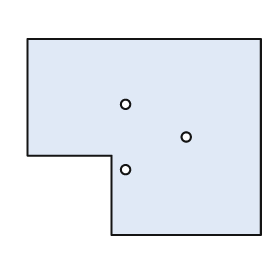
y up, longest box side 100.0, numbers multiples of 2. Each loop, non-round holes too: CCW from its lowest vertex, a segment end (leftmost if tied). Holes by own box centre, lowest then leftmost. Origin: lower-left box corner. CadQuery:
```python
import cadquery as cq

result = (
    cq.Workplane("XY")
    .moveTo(36.0, 0.0)
    .lineTo(100.0, 0.0)
    .lineTo(100.0, 84.0)
    .lineTo(0.0, 84.0)
    .lineTo(0.0, 34.0)
    .lineTo(36.0, 34.0)
    .close()
    .moveTo(42.0, 28.0)
    .circle(2.0)
    .moveTo(68.0, 42.0)
    .circle(2.0)
    .moveTo(42.0, 56.0)
    .circle(2.0)
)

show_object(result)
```